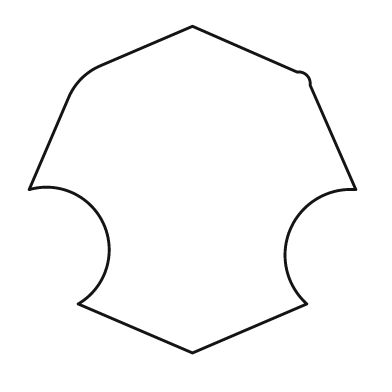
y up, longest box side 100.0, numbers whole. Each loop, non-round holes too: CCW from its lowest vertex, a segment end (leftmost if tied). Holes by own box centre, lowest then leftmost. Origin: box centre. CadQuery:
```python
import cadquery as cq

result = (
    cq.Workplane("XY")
    .moveTo(0.0, -50.0)
    .lineTo(35.0, -35.0)
    .threePointArc((30.0, -12.0), (50.0, 0.0))
    .lineTo(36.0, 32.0)
    .threePointArc((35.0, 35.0), (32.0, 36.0))
    .lineTo(0.0, 50.0)
    .lineTo(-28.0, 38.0)
    .threePointArc((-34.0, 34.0), (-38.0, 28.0))
    .lineTo(-50.0, 0.0)
    .threePointArc((-27.0, -11.0), (-35.0, -35.0))
    .close()
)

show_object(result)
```